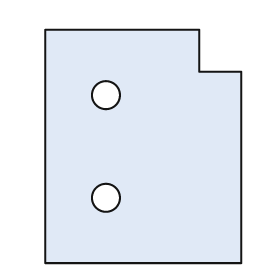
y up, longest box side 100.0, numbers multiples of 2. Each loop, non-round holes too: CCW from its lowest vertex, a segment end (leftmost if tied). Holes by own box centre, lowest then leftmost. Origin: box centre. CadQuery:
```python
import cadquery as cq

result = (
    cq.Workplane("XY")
    .moveTo(-42.0, -50.0)
    .lineTo(42.0, -50.0)
    .lineTo(42.0, 32.0)
    .lineTo(24.0, 32.0)
    .lineTo(24.0, 50.0)
    .lineTo(-42.0, 50.0)
    .close()
    .moveTo(-16.0, -22.0)
    .circle(6.0)
    .moveTo(-16.0, 22.0)
    .circle(6.0)
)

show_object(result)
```